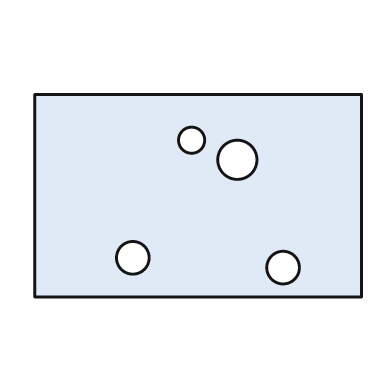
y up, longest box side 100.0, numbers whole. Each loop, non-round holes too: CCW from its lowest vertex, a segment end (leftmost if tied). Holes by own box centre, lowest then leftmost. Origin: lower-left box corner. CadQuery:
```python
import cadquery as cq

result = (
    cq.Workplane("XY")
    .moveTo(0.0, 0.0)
    .lineTo(100.0, 0.0)
    .lineTo(100.0, 62.0)
    .lineTo(0.0, 62.0)
    .close()
    .moveTo(76.0, 9.0)
    .circle(5.0)
    .moveTo(30.0, 12.0)
    .circle(5.0)
    .moveTo(62.0, 42.0)
    .circle(6.0)
    .moveTo(48.0, 48.0)
    .circle(4.0)
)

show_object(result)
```